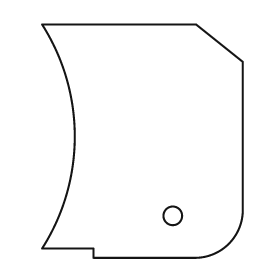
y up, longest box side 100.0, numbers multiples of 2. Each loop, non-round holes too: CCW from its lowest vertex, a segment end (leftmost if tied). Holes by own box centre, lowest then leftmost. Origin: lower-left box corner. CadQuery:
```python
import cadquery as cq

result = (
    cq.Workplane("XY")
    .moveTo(22.0, 0.0)
    .lineTo(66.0, 0.0)
    .threePointArc((80.0, 6.0), (86.0, 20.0))
    .lineTo(86.0, 84.0)
    .lineTo(66.0, 100.0)
    .lineTo(0.0, 100.0)
    .threePointArc((14.0, 52.0), (0.0, 4.0))
    .lineTo(22.0, 4.0)
    .close()
    .moveTo(56.0, 18.0)
    .circle(4.0)
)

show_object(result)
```